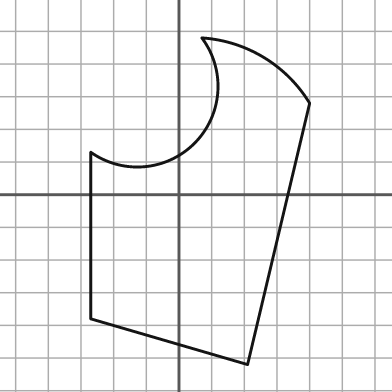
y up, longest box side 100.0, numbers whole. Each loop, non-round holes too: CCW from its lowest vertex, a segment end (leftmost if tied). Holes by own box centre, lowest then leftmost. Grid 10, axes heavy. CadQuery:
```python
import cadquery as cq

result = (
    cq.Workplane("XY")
    .moveTo(21.0, -52.0)
    .lineTo(40.0, 28.0)
    .threePointArc((26.0, 42.0), (7.0, 48.0))
    .threePointArc((5.0, 16.0), (-27.0, 13.0))
    .lineTo(-27.0, -38.0)
    .close()
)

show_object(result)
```